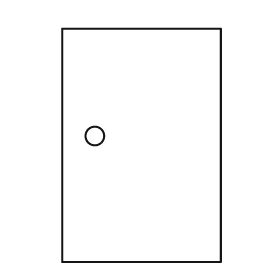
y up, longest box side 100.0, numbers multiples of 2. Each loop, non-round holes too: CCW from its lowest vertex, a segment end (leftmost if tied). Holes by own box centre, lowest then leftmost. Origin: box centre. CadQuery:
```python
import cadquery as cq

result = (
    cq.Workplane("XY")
    .moveTo(-34.0, -50.0)
    .lineTo(34.0, -50.0)
    .lineTo(34.0, 50.0)
    .lineTo(-34.0, 50.0)
    .close()
    .moveTo(-20.0, 4.0)
    .circle(4.0)
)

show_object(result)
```